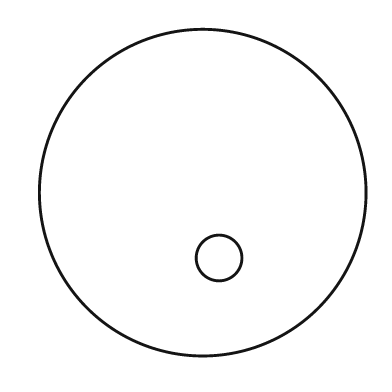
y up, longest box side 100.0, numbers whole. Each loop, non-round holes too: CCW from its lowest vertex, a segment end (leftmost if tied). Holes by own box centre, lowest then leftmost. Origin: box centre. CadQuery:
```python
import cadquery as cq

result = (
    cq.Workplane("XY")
    .moveTo(0.0, 0.0)
    .circle(50.0)
    .moveTo(5.0, -20.0)
    .circle(7.0)
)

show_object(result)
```